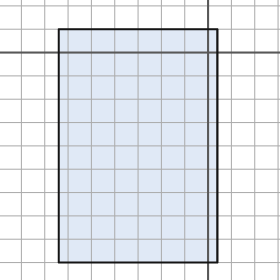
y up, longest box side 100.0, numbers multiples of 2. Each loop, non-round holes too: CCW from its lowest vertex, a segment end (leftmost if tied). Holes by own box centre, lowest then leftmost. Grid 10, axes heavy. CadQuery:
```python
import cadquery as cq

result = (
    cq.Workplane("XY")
    .moveTo(-64.0, -90.0)
    .lineTo(4.0, -90.0)
    .lineTo(4.0, 10.0)
    .lineTo(-64.0, 10.0)
    .close()
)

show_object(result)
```